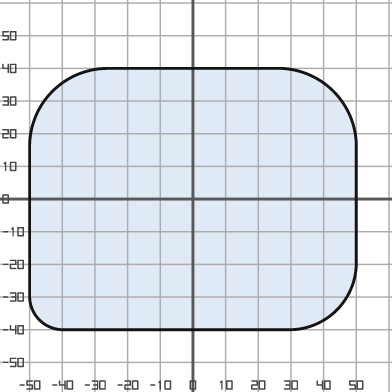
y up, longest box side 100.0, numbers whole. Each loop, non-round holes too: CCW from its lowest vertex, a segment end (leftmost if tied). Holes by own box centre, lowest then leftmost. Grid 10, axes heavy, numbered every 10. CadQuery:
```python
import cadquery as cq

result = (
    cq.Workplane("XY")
    .moveTo(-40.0, -40.0)
    .lineTo(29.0, -40.0)
    .threePointArc((44.0, -34.0), (50.0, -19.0))
    .lineTo(50.0, 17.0)
    .threePointArc((43.0, 33.0), (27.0, 40.0))
    .lineTo(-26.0, 40.0)
    .threePointArc((-43.0, 33.0), (-50.0, 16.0))
    .lineTo(-50.0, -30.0)
    .threePointArc((-47.0, -37.0), (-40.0, -40.0))
    .close()
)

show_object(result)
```